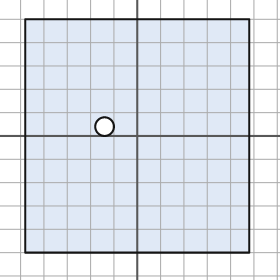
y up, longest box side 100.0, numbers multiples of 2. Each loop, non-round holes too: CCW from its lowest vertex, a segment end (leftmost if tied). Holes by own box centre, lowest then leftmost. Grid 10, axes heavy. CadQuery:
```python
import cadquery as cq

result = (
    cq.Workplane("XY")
    .moveTo(-48.0, -50.0)
    .lineTo(48.0, -50.0)
    .lineTo(48.0, 50.0)
    .lineTo(-48.0, 50.0)
    .close()
    .moveTo(-14.0, 4.0)
    .circle(4.0)
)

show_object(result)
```